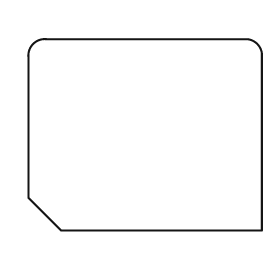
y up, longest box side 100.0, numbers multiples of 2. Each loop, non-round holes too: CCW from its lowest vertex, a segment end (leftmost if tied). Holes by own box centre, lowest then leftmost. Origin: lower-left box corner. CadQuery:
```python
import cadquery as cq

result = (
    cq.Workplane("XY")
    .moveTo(14.0, 0.0)
    .lineTo(100.0, 0.0)
    .lineTo(100.0, 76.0)
    .threePointArc((98.0, 80.0), (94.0, 82.0))
    .lineTo(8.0, 82.0)
    .threePointArc((2.0, 80.0), (0.0, 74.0))
    .lineTo(0.0, 14.0)
    .close()
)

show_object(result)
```